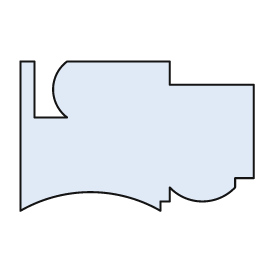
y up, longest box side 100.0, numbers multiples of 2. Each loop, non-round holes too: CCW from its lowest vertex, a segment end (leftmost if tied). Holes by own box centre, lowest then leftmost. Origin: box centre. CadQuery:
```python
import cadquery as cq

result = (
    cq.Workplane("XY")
    .moveTo(-50.0, -32.0)
    .threePointArc((-20.0, -24.0), (10.0, -32.0))
    .lineTo(10.0, -28.0)
    .lineTo(14.0, -28.0)
    .lineTo(14.0, -22.0)
    .threePointArc((28.0, -28.0), (42.0, -22.0))
    .lineTo(42.0, -18.0)
    .lineTo(50.0, -18.0)
    .lineTo(50.0, 22.0)
    .lineTo(14.0, 22.0)
    .lineTo(14.0, 32.0)
    .lineTo(-30.0, 32.0)
    .threePointArc((-36.0, 20.0), (-30.0, 8.0))
    .lineTo(-44.0, 8.0)
    .lineTo(-44.0, 32.0)
    .lineTo(-50.0, 32.0)
    .close()
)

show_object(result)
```